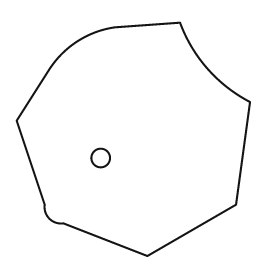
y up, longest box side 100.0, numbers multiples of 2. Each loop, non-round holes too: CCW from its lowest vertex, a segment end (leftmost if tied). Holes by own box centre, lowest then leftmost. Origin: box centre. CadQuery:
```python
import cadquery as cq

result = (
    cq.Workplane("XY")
    .moveTo(6.0, -50.0)
    .lineTo(44.0, -28.0)
    .lineTo(50.0, 16.0)
    .threePointArc((32.0, 30.0), (20.0, 50.0))
    .lineTo(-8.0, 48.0)
    .threePointArc((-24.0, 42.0), (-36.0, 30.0))
    .lineTo(-50.0, 8.0)
    .lineTo(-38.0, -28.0)
    .threePointArc((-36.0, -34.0), (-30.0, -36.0))
    .close()
    .moveTo(-14.0, -8.0)
    .circle(4.0)
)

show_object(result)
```